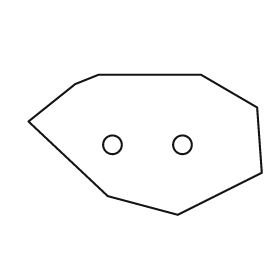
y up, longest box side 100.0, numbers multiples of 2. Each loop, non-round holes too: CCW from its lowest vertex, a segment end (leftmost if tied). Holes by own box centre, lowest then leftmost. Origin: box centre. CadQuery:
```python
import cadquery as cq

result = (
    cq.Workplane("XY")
    .moveTo(14.0, -30.0)
    .lineTo(50.0, -12.0)
    .lineTo(48.0, 16.0)
    .lineTo(24.0, 30.0)
    .lineTo(-20.0, 30.0)
    .lineTo(-30.0, 26.0)
    .lineTo(-50.0, 10.0)
    .lineTo(-16.0, -22.0)
    .close()
    .moveTo(-14.0, 0.0)
    .circle(4.0)
    .moveTo(16.0, 0.0)
    .circle(4.0)
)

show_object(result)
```